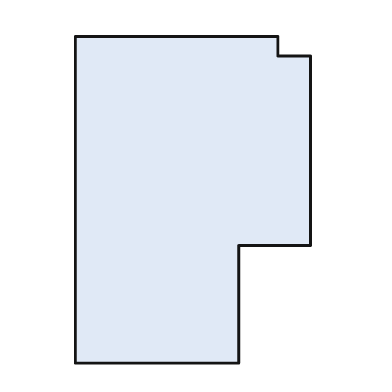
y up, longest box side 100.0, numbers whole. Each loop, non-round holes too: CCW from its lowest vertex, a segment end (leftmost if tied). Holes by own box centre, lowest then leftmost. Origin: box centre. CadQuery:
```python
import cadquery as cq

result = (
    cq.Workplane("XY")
    .moveTo(-36.0, -50.0)
    .lineTo(14.0, -50.0)
    .lineTo(14.0, -14.0)
    .lineTo(36.0, -14.0)
    .lineTo(36.0, 44.0)
    .lineTo(26.0, 44.0)
    .lineTo(26.0, 50.0)
    .lineTo(-36.0, 50.0)
    .close()
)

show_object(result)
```